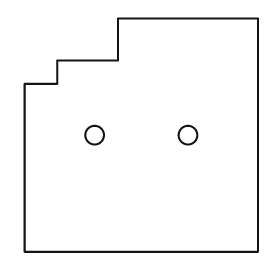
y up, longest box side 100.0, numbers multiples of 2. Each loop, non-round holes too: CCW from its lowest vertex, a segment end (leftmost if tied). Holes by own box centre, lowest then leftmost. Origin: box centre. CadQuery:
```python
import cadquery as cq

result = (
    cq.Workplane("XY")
    .moveTo(-50.0, -50.0)
    .lineTo(50.0, -50.0)
    .lineTo(50.0, 50.0)
    .lineTo(-10.0, 50.0)
    .lineTo(-10.0, 32.0)
    .lineTo(-36.0, 32.0)
    .lineTo(-36.0, 22.0)
    .lineTo(-50.0, 22.0)
    .close()
    .moveTo(-20.0, 0.0)
    .circle(4.0)
    .moveTo(20.0, 0.0)
    .circle(4.0)
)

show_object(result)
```